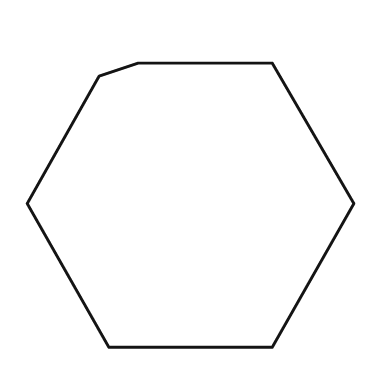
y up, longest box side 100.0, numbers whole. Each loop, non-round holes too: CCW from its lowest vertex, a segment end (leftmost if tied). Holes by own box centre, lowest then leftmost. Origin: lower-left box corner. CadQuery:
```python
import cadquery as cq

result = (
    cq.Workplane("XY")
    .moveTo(25.0, 0.0)
    .lineTo(75.0, 0.0)
    .lineTo(100.0, 44.0)
    .lineTo(75.0, 87.0)
    .lineTo(34.0, 87.0)
    .lineTo(22.0, 83.0)
    .lineTo(0.0, 44.0)
    .close()
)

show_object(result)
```